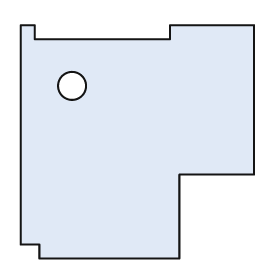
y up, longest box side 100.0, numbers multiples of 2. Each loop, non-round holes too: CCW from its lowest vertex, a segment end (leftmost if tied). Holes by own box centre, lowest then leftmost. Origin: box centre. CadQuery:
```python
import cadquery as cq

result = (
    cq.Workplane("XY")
    .moveTo(-42.0, -50.0)
    .lineTo(18.0, -50.0)
    .lineTo(18.0, -14.0)
    .lineTo(50.0, -14.0)
    .lineTo(50.0, 50.0)
    .lineTo(14.0, 50.0)
    .lineTo(14.0, 44.0)
    .lineTo(-44.0, 44.0)
    .lineTo(-44.0, 50.0)
    .lineTo(-50.0, 50.0)
    .lineTo(-50.0, -44.0)
    .lineTo(-42.0, -44.0)
    .close()
    .moveTo(-28.0, 24.0)
    .circle(6.0)
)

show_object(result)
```